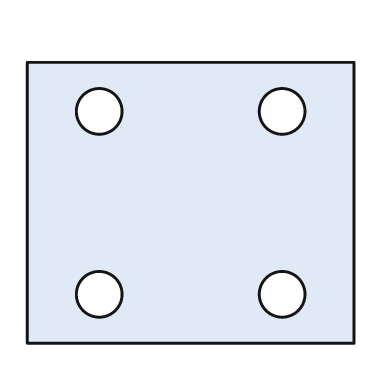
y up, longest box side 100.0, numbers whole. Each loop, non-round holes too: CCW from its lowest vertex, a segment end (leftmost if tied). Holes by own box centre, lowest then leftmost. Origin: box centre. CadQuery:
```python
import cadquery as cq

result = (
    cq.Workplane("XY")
    .moveTo(-50.0, -43.0)
    .lineTo(50.0, -43.0)
    .lineTo(50.0, 43.0)
    .lineTo(-50.0, 43.0)
    .close()
    .moveTo(-28.0, -28.0)
    .circle(7.0)
    .moveTo(28.0, -28.0)
    .circle(7.0)
    .moveTo(-28.0, 28.0)
    .circle(7.0)
    .moveTo(28.0, 28.0)
    .circle(7.0)
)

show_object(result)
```